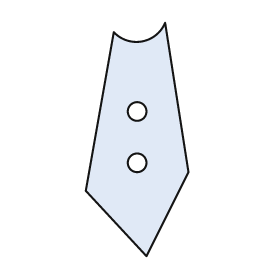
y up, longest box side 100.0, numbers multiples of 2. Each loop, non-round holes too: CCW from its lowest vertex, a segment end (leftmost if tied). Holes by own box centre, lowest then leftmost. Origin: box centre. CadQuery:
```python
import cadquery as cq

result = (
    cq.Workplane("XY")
    .moveTo(4.0, -50.0)
    .lineTo(22.0, -14.0)
    .lineTo(12.0, 50.0)
    .threePointArc((2.0, 42.0), (-10.0, 46.0))
    .lineTo(-22.0, -22.0)
    .close()
    .moveTo(0.0, -10.0)
    .circle(4.0)
    .moveTo(0.0, 12.0)
    .circle(4.0)
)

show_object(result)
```